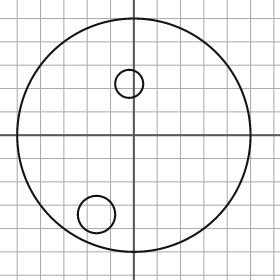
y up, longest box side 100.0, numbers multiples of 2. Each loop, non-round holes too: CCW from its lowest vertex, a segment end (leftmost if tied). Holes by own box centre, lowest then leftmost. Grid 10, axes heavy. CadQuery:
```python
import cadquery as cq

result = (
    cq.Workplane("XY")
    .moveTo(0.0, 0.0)
    .circle(50.0)
    .moveTo(-16.0, -34.0)
    .circle(8.0)
    .moveTo(-2.0, 22.0)
    .circle(6.0)
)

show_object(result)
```